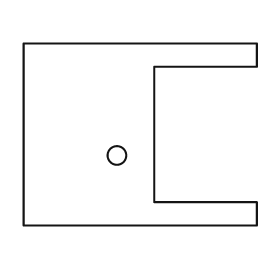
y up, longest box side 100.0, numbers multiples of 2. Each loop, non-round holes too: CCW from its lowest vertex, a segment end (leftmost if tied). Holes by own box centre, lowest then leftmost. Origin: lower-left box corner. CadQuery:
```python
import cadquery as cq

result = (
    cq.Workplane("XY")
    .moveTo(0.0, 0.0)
    .lineTo(100.0, 0.0)
    .lineTo(100.0, 10.0)
    .lineTo(56.0, 10.0)
    .lineTo(56.0, 68.0)
    .lineTo(100.0, 68.0)
    .lineTo(100.0, 78.0)
    .lineTo(0.0, 78.0)
    .close()
    .moveTo(40.0, 30.0)
    .circle(4.0)
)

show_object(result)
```